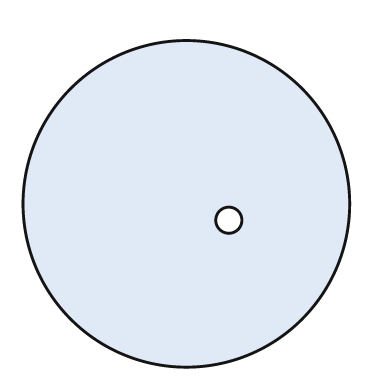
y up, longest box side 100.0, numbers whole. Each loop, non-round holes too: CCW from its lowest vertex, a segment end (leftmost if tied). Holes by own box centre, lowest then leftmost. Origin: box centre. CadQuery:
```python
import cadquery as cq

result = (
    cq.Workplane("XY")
    .moveTo(0.0, 0.0)
    .circle(50.0)
    .moveTo(13.0, -5.0)
    .circle(4.0)
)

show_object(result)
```